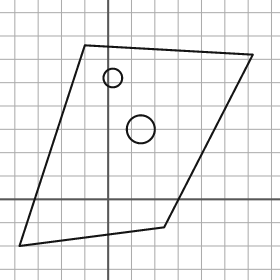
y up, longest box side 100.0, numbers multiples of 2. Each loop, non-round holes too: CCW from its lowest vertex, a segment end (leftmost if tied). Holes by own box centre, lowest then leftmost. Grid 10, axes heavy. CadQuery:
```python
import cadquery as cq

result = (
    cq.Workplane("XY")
    .moveTo(-38.0, -20.0)
    .lineTo(24.0, -12.0)
    .lineTo(62.0, 62.0)
    .lineTo(-10.0, 66.0)
    .close()
    .moveTo(14.0, 30.0)
    .circle(6.0)
    .moveTo(2.0, 52.0)
    .circle(4.0)
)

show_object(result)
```